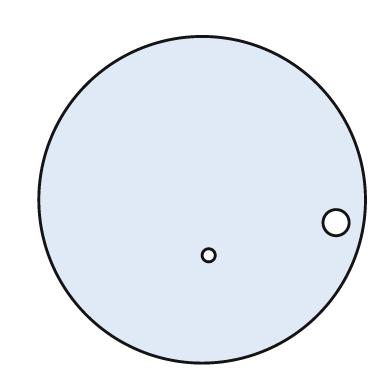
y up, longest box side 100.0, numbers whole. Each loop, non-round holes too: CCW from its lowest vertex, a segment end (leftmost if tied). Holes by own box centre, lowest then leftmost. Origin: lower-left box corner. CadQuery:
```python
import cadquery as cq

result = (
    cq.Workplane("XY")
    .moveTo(50.0, 50.0)
    .circle(50.0)
    .moveTo(52.0, 33.0)
    .circle(2.0)
    .moveTo(91.0, 43.0)
    .circle(4.0)
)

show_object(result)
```